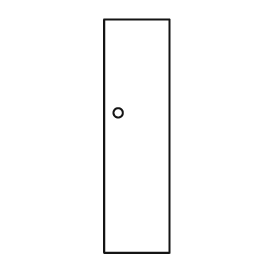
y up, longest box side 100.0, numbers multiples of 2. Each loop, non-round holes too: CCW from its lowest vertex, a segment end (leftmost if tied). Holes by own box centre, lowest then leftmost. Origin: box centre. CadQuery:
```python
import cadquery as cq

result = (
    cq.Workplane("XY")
    .moveTo(-14.0, -50.0)
    .lineTo(14.0, -50.0)
    .lineTo(14.0, 50.0)
    .lineTo(-14.0, 50.0)
    .close()
    .moveTo(-8.0, 10.0)
    .circle(2.0)
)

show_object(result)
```